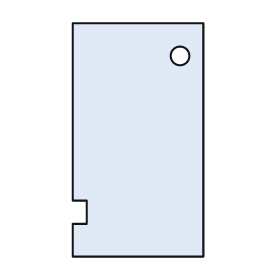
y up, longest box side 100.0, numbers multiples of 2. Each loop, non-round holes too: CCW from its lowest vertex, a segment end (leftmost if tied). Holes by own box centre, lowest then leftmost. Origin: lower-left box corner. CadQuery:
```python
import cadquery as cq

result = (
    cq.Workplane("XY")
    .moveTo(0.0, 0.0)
    .lineTo(56.0, 0.0)
    .lineTo(56.0, 100.0)
    .lineTo(0.0, 100.0)
    .lineTo(0.0, 24.0)
    .lineTo(6.0, 24.0)
    .lineTo(6.0, 14.0)
    .lineTo(0.0, 14.0)
    .close()
    .moveTo(46.0, 86.0)
    .circle(4.0)
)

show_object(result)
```